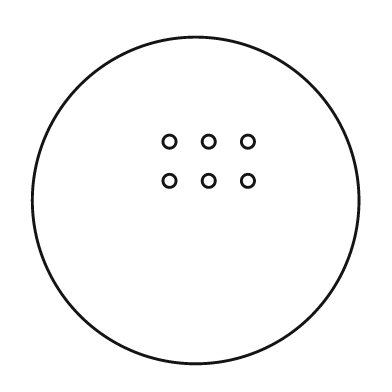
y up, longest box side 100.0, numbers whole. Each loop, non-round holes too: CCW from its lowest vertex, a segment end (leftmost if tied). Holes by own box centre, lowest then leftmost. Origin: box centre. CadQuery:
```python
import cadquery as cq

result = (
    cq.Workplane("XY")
    .moveTo(0.0, 0.0)
    .circle(50.0)
    .moveTo(-8.0, 6.0)
    .circle(2.0)
    .moveTo(4.0, 6.0)
    .circle(2.0)
    .moveTo(16.0, 6.0)
    .circle(2.0)
    .moveTo(-8.0, 18.0)
    .circle(2.0)
    .moveTo(4.0, 18.0)
    .circle(2.0)
    .moveTo(16.0, 18.0)
    .circle(2.0)
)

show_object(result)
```